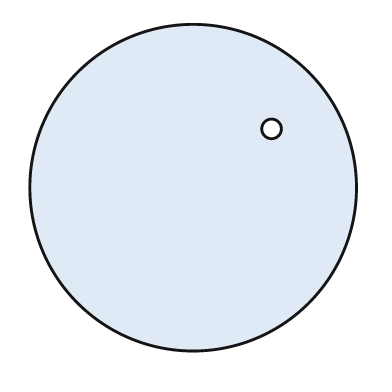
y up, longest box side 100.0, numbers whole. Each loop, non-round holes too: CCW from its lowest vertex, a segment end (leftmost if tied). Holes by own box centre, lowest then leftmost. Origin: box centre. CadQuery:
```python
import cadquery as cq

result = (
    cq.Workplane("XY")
    .moveTo(0.0, 0.0)
    .circle(50.0)
    .moveTo(24.0, 18.0)
    .circle(3.0)
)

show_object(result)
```